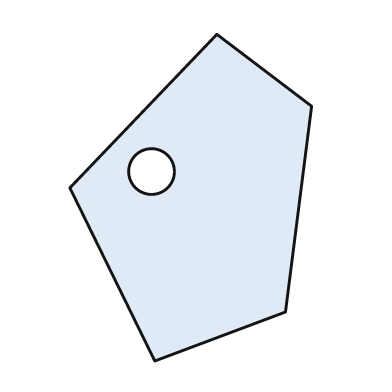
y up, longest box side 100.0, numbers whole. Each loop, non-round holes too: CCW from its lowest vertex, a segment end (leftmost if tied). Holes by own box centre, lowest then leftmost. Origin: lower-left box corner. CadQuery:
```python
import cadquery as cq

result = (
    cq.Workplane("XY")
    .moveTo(26.0, 0.0)
    .lineTo(66.0, 15.0)
    .lineTo(74.0, 78.0)
    .lineTo(45.0, 100.0)
    .lineTo(0.0, 53.0)
    .close()
    .moveTo(25.0, 58.0)
    .circle(7.0)
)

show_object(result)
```